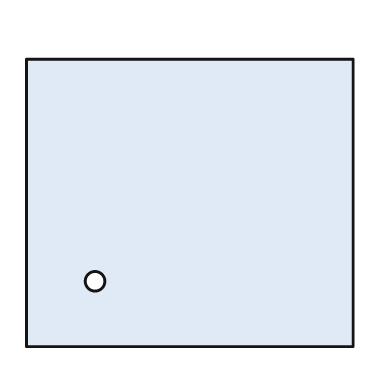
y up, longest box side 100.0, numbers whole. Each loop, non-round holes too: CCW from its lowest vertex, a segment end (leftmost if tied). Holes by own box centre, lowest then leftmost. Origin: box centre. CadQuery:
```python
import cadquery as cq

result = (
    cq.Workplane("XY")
    .moveTo(-50.0, -44.0)
    .lineTo(50.0, -44.0)
    .lineTo(50.0, 44.0)
    .lineTo(-50.0, 44.0)
    .close()
    .moveTo(-29.0, -24.0)
    .circle(3.0)
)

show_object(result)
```